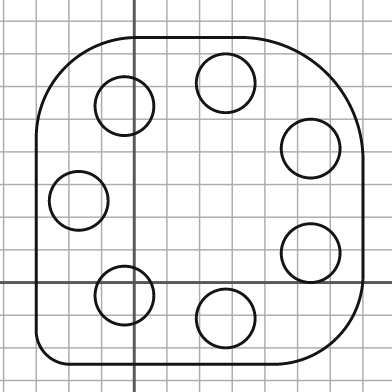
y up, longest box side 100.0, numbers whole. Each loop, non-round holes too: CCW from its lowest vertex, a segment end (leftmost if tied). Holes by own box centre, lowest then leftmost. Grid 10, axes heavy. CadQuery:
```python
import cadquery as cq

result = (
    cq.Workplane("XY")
    .moveTo(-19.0, -25.0)
    .lineTo(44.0, -25.0)
    .threePointArc((62.0, -17.0), (70.0, 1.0))
    .lineTo(70.0, 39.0)
    .threePointArc((59.0, 64.0), (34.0, 75.0))
    .lineTo(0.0, 75.0)
    .threePointArc((-21.0, 66.0), (-30.0, 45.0))
    .lineTo(-30.0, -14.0)
    .threePointArc((-27.0, -22.0), (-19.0, -25.0))
    .close()
    .moveTo(28.0, -11.0)
    .circle(9.0)
    .moveTo(-3.0, -4.0)
    .circle(9.0)
    .moveTo(54.0, 9.0)
    .circle(9.0)
    .moveTo(-17.0, 25.0)
    .circle(9.0)
    .moveTo(54.0, 41.0)
    .circle(9.0)
    .moveTo(-3.0, 54.0)
    .circle(9.0)
    .moveTo(28.0, 61.0)
    .circle(9.0)
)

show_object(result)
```